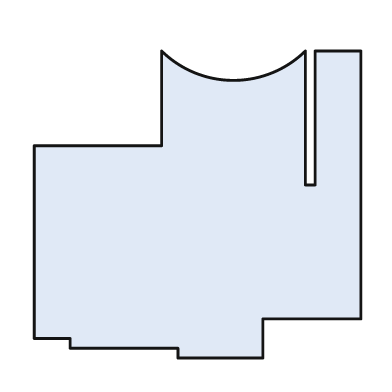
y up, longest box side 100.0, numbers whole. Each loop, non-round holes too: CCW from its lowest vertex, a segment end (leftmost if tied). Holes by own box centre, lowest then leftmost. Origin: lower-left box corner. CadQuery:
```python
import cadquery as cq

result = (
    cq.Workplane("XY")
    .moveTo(44.0, 0.0)
    .lineTo(70.0, 0.0)
    .lineTo(70.0, 12.0)
    .lineTo(100.0, 12.0)
    .lineTo(100.0, 94.0)
    .lineTo(86.0, 94.0)
    .lineTo(86.0, 53.0)
    .lineTo(83.0, 53.0)
    .lineTo(83.0, 94.0)
    .threePointArc((61.0, 85.0), (39.0, 94.0))
    .lineTo(39.0, 65.0)
    .lineTo(0.0, 65.0)
    .lineTo(0.0, 6.0)
    .lineTo(11.0, 6.0)
    .lineTo(11.0, 3.0)
    .lineTo(44.0, 3.0)
    .close()
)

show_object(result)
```